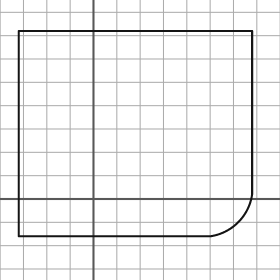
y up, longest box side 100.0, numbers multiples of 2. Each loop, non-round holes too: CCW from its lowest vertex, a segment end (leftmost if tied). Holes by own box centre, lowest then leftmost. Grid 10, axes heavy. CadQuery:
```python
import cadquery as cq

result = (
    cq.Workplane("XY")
    .moveTo(-32.0, -16.0)
    .lineTo(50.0, -16.0)
    .threePointArc((62.0, -10.0), (68.0, 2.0))
    .lineTo(68.0, 72.0)
    .lineTo(-32.0, 72.0)
    .close()
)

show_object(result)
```